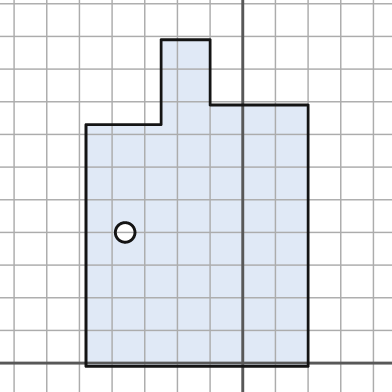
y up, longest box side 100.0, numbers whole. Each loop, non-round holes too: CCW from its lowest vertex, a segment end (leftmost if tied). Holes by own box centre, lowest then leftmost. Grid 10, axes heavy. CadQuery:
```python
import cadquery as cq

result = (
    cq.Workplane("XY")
    .moveTo(-48.0, -1.0)
    .lineTo(20.0, -1.0)
    .lineTo(20.0, 79.0)
    .lineTo(-10.0, 79.0)
    .lineTo(-10.0, 99.0)
    .lineTo(-25.0, 99.0)
    .lineTo(-25.0, 73.0)
    .lineTo(-48.0, 73.0)
    .close()
    .moveTo(-36.0, 40.0)
    .circle(3.0)
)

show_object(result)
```